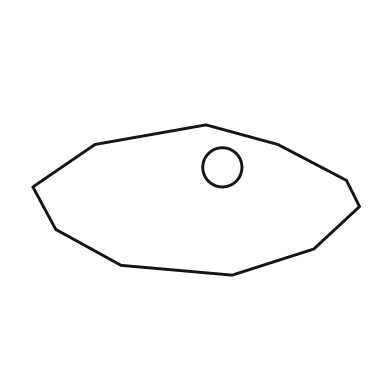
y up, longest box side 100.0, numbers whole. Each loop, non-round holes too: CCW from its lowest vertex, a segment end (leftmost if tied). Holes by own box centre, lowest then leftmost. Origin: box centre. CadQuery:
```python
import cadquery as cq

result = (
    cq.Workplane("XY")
    .moveTo(11.0, -23.0)
    .lineTo(36.0, -15.0)
    .lineTo(50.0, -2.0)
    .lineTo(46.0, 6.0)
    .lineTo(25.0, 17.0)
    .lineTo(3.0, 23.0)
    .lineTo(-31.0, 17.0)
    .lineTo(-50.0, 4.0)
    .lineTo(-43.0, -9.0)
    .lineTo(-23.0, -20.0)
    .close()
    .moveTo(8.0, 10.0)
    .circle(6.0)
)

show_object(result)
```